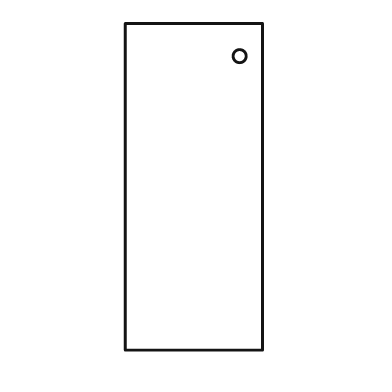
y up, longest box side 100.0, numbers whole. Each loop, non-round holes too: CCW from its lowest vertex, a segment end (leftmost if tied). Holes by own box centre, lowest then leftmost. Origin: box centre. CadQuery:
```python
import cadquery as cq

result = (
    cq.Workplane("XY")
    .moveTo(-21.0, -50.0)
    .lineTo(21.0, -50.0)
    .lineTo(21.0, 50.0)
    .lineTo(-21.0, 50.0)
    .close()
    .moveTo(14.0, 40.0)
    .circle(2.0)
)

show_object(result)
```